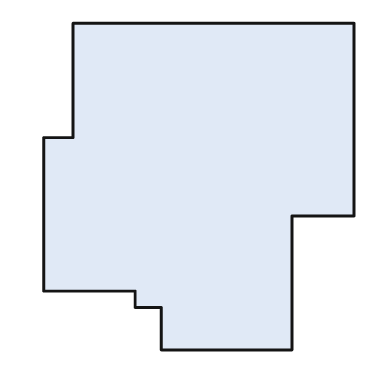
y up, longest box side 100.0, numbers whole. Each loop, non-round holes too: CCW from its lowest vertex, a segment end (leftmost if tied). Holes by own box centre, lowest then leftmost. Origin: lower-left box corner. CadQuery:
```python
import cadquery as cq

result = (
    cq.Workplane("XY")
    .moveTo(36.0, 0.0)
    .lineTo(76.0, 0.0)
    .lineTo(76.0, 41.0)
    .lineTo(95.0, 41.0)
    .lineTo(95.0, 100.0)
    .lineTo(9.0, 100.0)
    .lineTo(9.0, 65.0)
    .lineTo(0.0, 65.0)
    .lineTo(0.0, 18.0)
    .lineTo(28.0, 18.0)
    .lineTo(28.0, 13.0)
    .lineTo(36.0, 13.0)
    .close()
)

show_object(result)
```